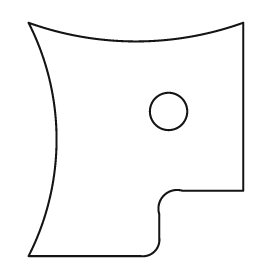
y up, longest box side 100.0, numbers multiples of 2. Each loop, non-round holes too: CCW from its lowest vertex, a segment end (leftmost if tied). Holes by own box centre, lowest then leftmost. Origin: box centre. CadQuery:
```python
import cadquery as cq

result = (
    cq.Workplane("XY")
    .moveTo(-46.0, -50.0)
    .lineTo(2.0, -50.0)
    .threePointArc((8.0, -48.0), (10.0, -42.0))
    .lineTo(10.0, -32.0)
    .threePointArc((12.0, -24.0), (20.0, -22.0))
    .lineTo(46.0, -22.0)
    .lineTo(46.0, 50.0)
    .threePointArc((0.0, 42.0), (-46.0, 50.0))
    .threePointArc((-34.0, 0.0), (-46.0, -50.0))
    .close()
    .moveTo(14.0, 12.0)
    .circle(8.0)
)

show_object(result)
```